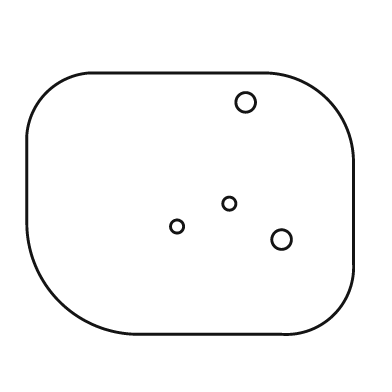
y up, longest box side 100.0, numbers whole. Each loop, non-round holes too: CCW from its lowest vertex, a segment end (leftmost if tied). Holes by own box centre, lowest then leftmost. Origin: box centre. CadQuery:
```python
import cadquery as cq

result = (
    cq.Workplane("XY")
    .moveTo(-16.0, -40.0)
    .lineTo(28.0, -40.0)
    .threePointArc((44.0, -34.0), (50.0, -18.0))
    .lineTo(50.0, 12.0)
    .threePointArc((42.0, 32.0), (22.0, 40.0))
    .lineTo(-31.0, 40.0)
    .threePointArc((-44.0, 34.0), (-50.0, 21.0))
    .lineTo(-50.0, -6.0)
    .threePointArc((-40.0, -30.0), (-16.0, -40.0))
    .close()
    .moveTo(28.0, -11.0)
    .circle(3.0)
    .moveTo(-4.0, -7.0)
    .circle(2.0)
    .moveTo(12.0, 0.0)
    .circle(2.0)
    .moveTo(17.0, 31.0)
    .circle(3.0)
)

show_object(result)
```